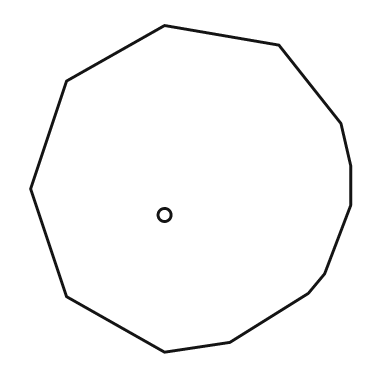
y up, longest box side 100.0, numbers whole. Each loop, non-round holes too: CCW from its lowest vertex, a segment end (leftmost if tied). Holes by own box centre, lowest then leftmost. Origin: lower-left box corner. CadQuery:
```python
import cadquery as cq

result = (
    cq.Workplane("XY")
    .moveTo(41.0, 0.0)
    .lineTo(61.0, 3.0)
    .lineTo(85.0, 18.0)
    .lineTo(90.0, 24.0)
    .lineTo(98.0, 45.0)
    .lineTo(98.0, 57.0)
    .lineTo(95.0, 70.0)
    .lineTo(76.0, 94.0)
    .lineTo(41.0, 100.0)
    .lineTo(11.0, 83.0)
    .lineTo(0.0, 50.0)
    .lineTo(11.0, 17.0)
    .close()
    .moveTo(41.0, 42.0)
    .circle(2.0)
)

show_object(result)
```